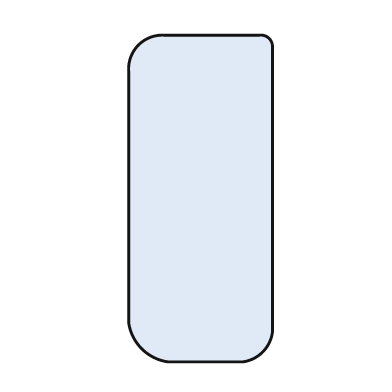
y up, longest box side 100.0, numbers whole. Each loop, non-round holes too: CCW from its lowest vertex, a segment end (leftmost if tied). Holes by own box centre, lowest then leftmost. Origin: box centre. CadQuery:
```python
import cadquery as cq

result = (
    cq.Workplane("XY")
    .moveTo(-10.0, -50.0)
    .lineTo(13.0, -50.0)
    .threePointArc((19.0, -47.0), (22.0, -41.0))
    .lineTo(22.0, 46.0)
    .threePointArc((21.0, 49.0), (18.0, 50.0))
    .lineTo(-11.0, 50.0)
    .threePointArc((-19.0, 47.0), (-22.0, 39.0))
    .lineTo(-22.0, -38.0)
    .threePointArc((-18.0, -46.0), (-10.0, -50.0))
    .close()
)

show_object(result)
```